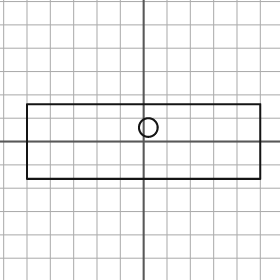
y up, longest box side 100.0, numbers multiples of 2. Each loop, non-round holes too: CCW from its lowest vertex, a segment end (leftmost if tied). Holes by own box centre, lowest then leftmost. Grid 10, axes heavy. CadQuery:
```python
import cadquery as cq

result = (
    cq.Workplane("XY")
    .moveTo(-50.0, -16.0)
    .lineTo(50.0, -16.0)
    .lineTo(50.0, 16.0)
    .lineTo(-50.0, 16.0)
    .close()
    .moveTo(2.0, 6.0)
    .circle(4.0)
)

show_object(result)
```